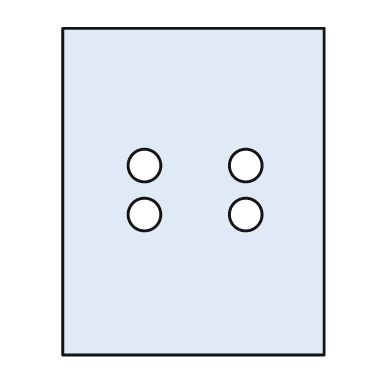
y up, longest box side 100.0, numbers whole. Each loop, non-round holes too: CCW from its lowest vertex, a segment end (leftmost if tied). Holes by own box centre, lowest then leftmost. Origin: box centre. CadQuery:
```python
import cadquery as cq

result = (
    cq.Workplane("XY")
    .moveTo(-40.0, -50.0)
    .lineTo(40.0, -50.0)
    .lineTo(40.0, 50.0)
    .lineTo(-40.0, 50.0)
    .close()
    .moveTo(-15.0, -7.0)
    .circle(5.0)
    .moveTo(16.0, -7.0)
    .circle(5.0)
    .moveTo(-15.0, 8.0)
    .circle(5.0)
    .moveTo(16.0, 8.0)
    .circle(5.0)
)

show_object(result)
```